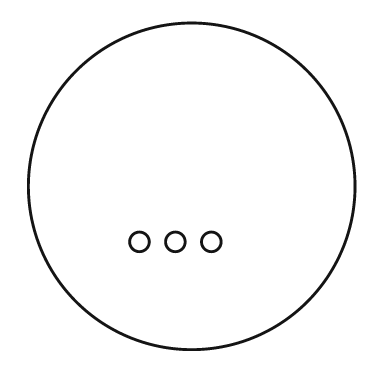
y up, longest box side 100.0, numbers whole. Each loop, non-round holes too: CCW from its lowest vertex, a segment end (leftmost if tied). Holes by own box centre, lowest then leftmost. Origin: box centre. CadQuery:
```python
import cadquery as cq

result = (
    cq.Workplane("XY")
    .moveTo(0.0, 0.0)
    .circle(50.0)
    .moveTo(-16.0, -17.0)
    .circle(3.0)
    .moveTo(-5.0, -17.0)
    .circle(3.0)
    .moveTo(6.0, -17.0)
    .circle(3.0)
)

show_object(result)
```